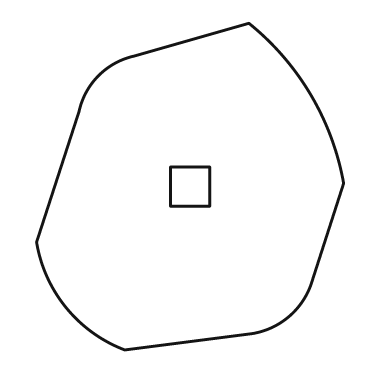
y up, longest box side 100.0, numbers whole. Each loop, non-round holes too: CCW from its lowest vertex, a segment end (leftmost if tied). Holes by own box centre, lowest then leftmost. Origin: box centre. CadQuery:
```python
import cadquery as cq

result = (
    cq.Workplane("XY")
    .moveTo(-20.0, -50.0)
    .lineTo(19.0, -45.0)
    .threePointArc((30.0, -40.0), (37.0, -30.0))
    .lineTo(47.0, 1.0)
    .threePointArc((37.0, 28.0), (18.0, 50.0))
    .lineTo(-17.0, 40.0)
    .threePointArc((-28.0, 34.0), (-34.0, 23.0))
    .lineTo(-47.0, -17.0)
    .threePointArc((-38.0, -37.0), (-20.0, -50.0))
    .close()
    .moveTo(-6.0, -6.0)
    .lineTo(6.0, -6.0)
    .lineTo(6.0, 6.0)
    .lineTo(-6.0, 6.0)
    .close()
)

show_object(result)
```